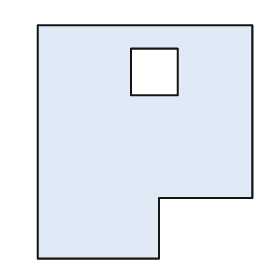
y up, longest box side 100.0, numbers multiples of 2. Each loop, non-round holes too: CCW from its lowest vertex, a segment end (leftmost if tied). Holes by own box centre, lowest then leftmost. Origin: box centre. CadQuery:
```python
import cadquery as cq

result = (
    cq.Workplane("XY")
    .moveTo(-46.0, -50.0)
    .lineTo(6.0, -50.0)
    .lineTo(6.0, -24.0)
    .lineTo(46.0, -24.0)
    .lineTo(46.0, 50.0)
    .lineTo(-46.0, 50.0)
    .close()
    .moveTo(-6.0, 20.0)
    .lineTo(14.0, 20.0)
    .lineTo(14.0, 40.0)
    .lineTo(-6.0, 40.0)
    .close()
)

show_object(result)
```